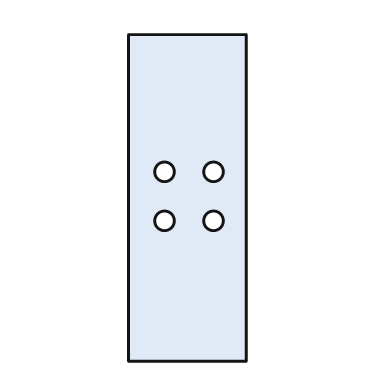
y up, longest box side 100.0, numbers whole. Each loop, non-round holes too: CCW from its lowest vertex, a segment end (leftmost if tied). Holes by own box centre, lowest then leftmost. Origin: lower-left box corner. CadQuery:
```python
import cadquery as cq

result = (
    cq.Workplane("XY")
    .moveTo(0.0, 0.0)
    .lineTo(36.0, 0.0)
    .lineTo(36.0, 100.0)
    .lineTo(0.0, 100.0)
    .close()
    .moveTo(11.0, 43.0)
    .circle(3.0)
    .moveTo(26.0, 43.0)
    .circle(3.0)
    .moveTo(11.0, 58.0)
    .circle(3.0)
    .moveTo(26.0, 58.0)
    .circle(3.0)
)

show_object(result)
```